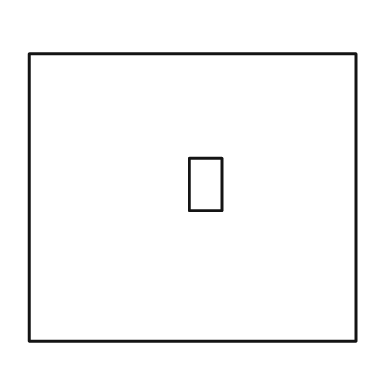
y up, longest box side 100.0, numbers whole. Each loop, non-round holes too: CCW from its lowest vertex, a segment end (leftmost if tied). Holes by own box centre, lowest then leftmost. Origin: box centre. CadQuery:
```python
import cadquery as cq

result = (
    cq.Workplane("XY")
    .moveTo(-50.0, -44.0)
    .lineTo(50.0, -44.0)
    .lineTo(50.0, 44.0)
    .lineTo(-50.0, 44.0)
    .close()
    .moveTo(-1.0, -4.0)
    .lineTo(9.0, -4.0)
    .lineTo(9.0, 12.0)
    .lineTo(-1.0, 12.0)
    .close()
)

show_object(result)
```